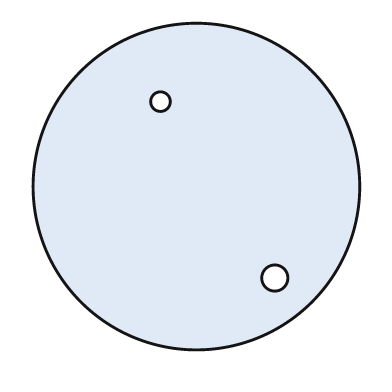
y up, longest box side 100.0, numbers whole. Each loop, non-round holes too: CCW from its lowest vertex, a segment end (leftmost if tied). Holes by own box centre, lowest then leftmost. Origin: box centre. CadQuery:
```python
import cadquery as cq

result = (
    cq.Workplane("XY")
    .moveTo(0.0, 0.0)
    .circle(50.0)
    .moveTo(24.0, -28.0)
    .circle(4.0)
    .moveTo(-11.0, 26.0)
    .circle(3.0)
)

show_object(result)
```